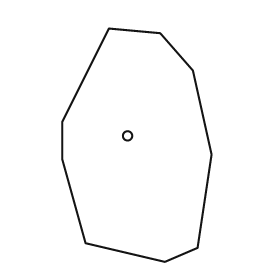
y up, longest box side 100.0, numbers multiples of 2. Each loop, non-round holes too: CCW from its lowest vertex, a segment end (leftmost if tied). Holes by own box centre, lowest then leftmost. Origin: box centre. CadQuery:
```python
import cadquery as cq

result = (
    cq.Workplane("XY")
    .moveTo(12.0, -50.0)
    .lineTo(26.0, -44.0)
    .lineTo(32.0, -4.0)
    .lineTo(24.0, 32.0)
    .lineTo(10.0, 48.0)
    .lineTo(-12.0, 50.0)
    .lineTo(-32.0, 10.0)
    .lineTo(-32.0, -6.0)
    .lineTo(-22.0, -42.0)
    .close()
    .moveTo(-4.0, 4.0)
    .circle(2.0)
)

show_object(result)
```